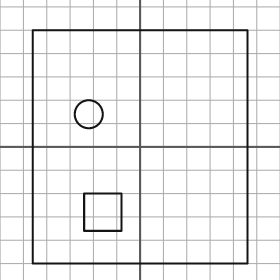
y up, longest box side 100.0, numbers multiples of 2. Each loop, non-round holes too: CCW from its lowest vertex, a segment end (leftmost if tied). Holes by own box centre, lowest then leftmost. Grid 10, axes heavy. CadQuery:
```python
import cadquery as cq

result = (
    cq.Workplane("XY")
    .moveTo(-46.0, -50.0)
    .lineTo(46.0, -50.0)
    .lineTo(46.0, 50.0)
    .lineTo(-46.0, 50.0)
    .close()
    .moveTo(-24.0, -36.0)
    .lineTo(-8.0, -36.0)
    .lineTo(-8.0, -20.0)
    .lineTo(-24.0, -20.0)
    .close()
    .moveTo(-22.0, 14.0)
    .circle(6.0)
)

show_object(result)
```